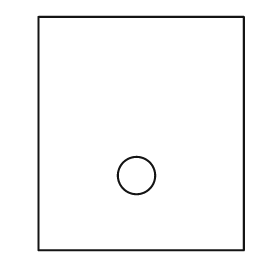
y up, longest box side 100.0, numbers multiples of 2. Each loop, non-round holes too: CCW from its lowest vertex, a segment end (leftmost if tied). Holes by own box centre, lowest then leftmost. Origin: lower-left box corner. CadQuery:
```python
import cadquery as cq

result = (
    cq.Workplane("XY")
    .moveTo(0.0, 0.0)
    .lineTo(88.0, 0.0)
    .lineTo(88.0, 100.0)
    .lineTo(0.0, 100.0)
    .close()
    .moveTo(42.0, 32.0)
    .circle(8.0)
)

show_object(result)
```